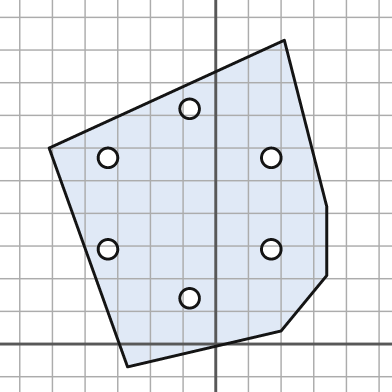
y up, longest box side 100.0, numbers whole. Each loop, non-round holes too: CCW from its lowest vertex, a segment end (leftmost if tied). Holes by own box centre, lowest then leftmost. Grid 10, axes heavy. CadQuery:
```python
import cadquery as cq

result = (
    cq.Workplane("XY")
    .moveTo(-27.0, -7.0)
    .lineTo(20.0, 4.0)
    .lineTo(34.0, 21.0)
    .lineTo(34.0, 42.0)
    .lineTo(21.0, 93.0)
    .lineTo(-51.0, 60.0)
    .close()
    .moveTo(-8.0, 14.0)
    .circle(3.0)
    .moveTo(-33.0, 29.0)
    .circle(3.0)
    .moveTo(17.0, 29.0)
    .circle(3.0)
    .moveTo(-33.0, 57.0)
    .circle(3.0)
    .moveTo(17.0, 57.0)
    .circle(3.0)
    .moveTo(-8.0, 72.0)
    .circle(3.0)
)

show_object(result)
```